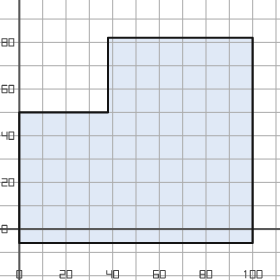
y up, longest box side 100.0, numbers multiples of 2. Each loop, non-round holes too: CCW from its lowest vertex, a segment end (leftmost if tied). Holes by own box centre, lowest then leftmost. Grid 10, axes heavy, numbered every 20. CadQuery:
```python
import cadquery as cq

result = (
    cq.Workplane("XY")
    .moveTo(0.0, -6.0)
    .lineTo(100.0, -6.0)
    .lineTo(100.0, 82.0)
    .lineTo(38.0, 82.0)
    .lineTo(38.0, 50.0)
    .lineTo(0.0, 50.0)
    .close()
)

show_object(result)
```